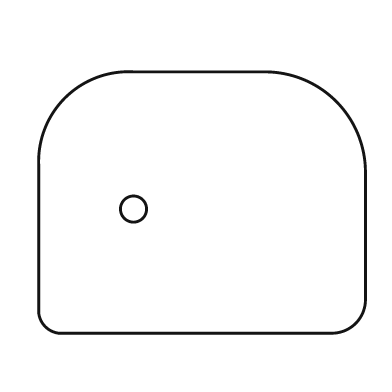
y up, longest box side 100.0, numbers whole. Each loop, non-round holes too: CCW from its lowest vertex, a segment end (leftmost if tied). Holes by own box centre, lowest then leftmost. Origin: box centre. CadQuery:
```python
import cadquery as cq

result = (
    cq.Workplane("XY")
    .moveTo(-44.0, -40.0)
    .lineTo(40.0, -40.0)
    .threePointArc((47.0, -37.0), (50.0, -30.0))
    .lineTo(50.0, 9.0)
    .threePointArc((41.0, 31.0), (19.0, 40.0))
    .lineTo(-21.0, 40.0)
    .threePointArc((-42.0, 32.0), (-50.0, 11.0))
    .lineTo(-50.0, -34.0)
    .threePointArc((-48.0, -38.0), (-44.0, -40.0))
    .close()
    .moveTo(-21.0, -2.0)
    .circle(4.0)
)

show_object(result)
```